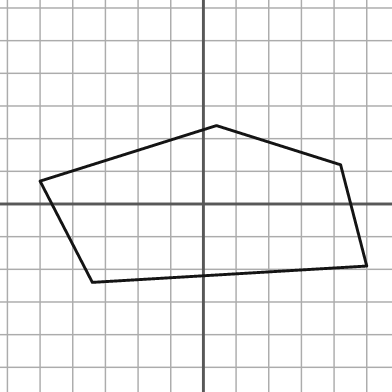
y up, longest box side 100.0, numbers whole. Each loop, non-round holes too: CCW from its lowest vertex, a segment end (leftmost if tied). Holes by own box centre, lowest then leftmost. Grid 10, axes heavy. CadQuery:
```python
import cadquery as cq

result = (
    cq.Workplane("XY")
    .moveTo(-34.0, -24.0)
    .lineTo(50.0, -19.0)
    .lineTo(42.0, 12.0)
    .lineTo(4.0, 24.0)
    .lineTo(-50.0, 7.0)
    .close()
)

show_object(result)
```